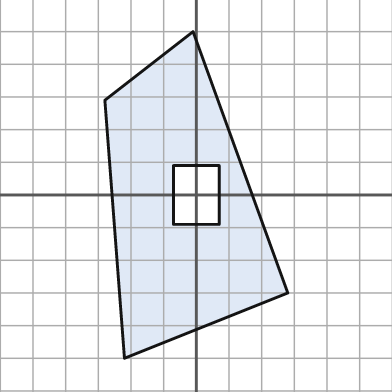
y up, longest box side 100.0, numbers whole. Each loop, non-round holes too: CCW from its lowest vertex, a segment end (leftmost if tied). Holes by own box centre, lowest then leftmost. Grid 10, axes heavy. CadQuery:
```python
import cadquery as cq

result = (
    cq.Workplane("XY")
    .moveTo(-22.0, -50.0)
    .lineTo(28.0, -30.0)
    .lineTo(-1.0, 50.0)
    .lineTo(-28.0, 29.0)
    .close()
    .moveTo(-7.0, -9.0)
    .lineTo(7.0, -9.0)
    .lineTo(7.0, 9.0)
    .lineTo(-7.0, 9.0)
    .close()
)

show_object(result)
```